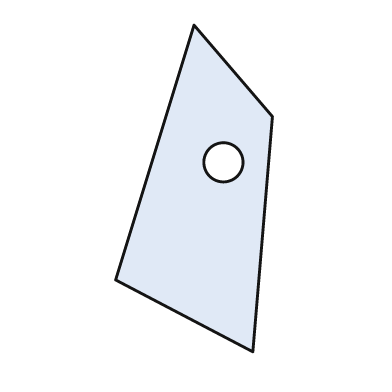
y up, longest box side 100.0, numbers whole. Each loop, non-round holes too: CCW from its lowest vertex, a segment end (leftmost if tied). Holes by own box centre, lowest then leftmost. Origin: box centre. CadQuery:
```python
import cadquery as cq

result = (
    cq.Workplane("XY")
    .moveTo(18.0, -50.0)
    .lineTo(24.0, 22.0)
    .lineTo(0.0, 50.0)
    .lineTo(-24.0, -28.0)
    .close()
    .moveTo(9.0, 8.0)
    .circle(6.0)
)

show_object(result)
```